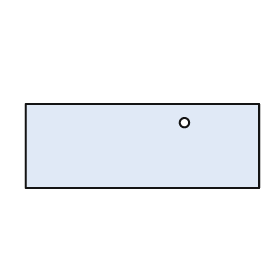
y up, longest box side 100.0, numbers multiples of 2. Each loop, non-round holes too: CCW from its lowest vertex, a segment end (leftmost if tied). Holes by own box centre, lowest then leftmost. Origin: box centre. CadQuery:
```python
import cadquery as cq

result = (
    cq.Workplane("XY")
    .moveTo(-50.0, -18.0)
    .lineTo(50.0, -18.0)
    .lineTo(50.0, 18.0)
    .lineTo(-50.0, 18.0)
    .close()
    .moveTo(18.0, 10.0)
    .circle(2.0)
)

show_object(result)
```